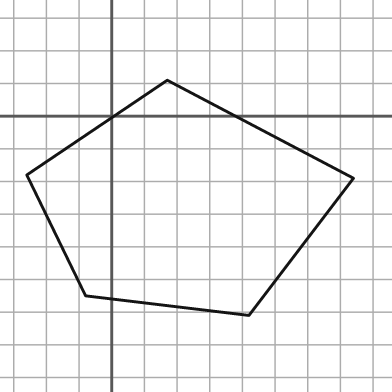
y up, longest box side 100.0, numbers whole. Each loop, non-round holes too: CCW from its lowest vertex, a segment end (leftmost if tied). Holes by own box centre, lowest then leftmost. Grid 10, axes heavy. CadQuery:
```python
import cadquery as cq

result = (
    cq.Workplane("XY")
    .moveTo(42.0, -61.0)
    .lineTo(74.0, -19.0)
    .lineTo(17.0, 11.0)
    .lineTo(-26.0, -18.0)
    .lineTo(-8.0, -55.0)
    .close()
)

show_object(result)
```